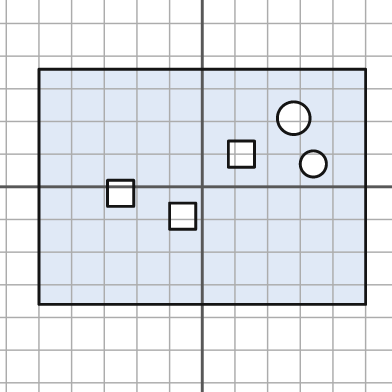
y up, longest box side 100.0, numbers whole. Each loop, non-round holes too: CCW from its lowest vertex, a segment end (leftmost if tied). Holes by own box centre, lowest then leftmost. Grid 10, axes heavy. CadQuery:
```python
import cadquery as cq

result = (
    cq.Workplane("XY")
    .moveTo(-50.0, -36.0)
    .lineTo(50.0, -36.0)
    .lineTo(50.0, 36.0)
    .lineTo(-50.0, 36.0)
    .close()
    .moveTo(-10.0, -13.0)
    .lineTo(-2.0, -13.0)
    .lineTo(-2.0, -5.0)
    .lineTo(-10.0, -5.0)
    .close()
    .moveTo(-29.0, -6.0)
    .lineTo(-21.0, -6.0)
    .lineTo(-21.0, 2.0)
    .lineTo(-29.0, 2.0)
    .close()
    .moveTo(34.0, 7.0)
    .circle(4.0)
    .moveTo(8.0, 6.0)
    .lineTo(16.0, 6.0)
    .lineTo(16.0, 14.0)
    .lineTo(8.0, 14.0)
    .close()
    .moveTo(28.0, 21.0)
    .circle(5.0)
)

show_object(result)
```